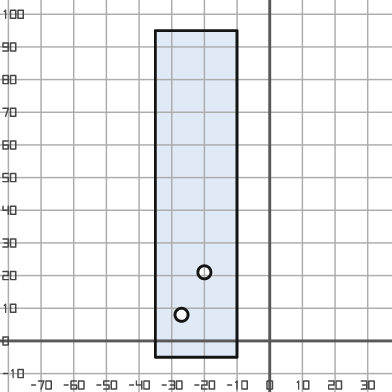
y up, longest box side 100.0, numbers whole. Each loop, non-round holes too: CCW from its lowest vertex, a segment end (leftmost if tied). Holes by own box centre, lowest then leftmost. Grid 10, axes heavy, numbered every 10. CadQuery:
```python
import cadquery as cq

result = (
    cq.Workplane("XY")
    .moveTo(-35.0, -5.0)
    .lineTo(-10.0, -5.0)
    .lineTo(-10.0, 95.0)
    .lineTo(-35.0, 95.0)
    .close()
    .moveTo(-27.0, 8.0)
    .circle(2.0)
    .moveTo(-20.0, 21.0)
    .circle(2.0)
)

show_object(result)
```